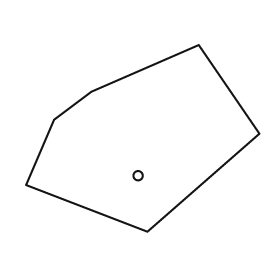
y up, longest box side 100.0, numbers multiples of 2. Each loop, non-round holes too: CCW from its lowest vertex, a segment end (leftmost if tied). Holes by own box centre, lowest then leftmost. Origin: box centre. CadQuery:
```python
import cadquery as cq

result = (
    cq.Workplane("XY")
    .moveTo(2.0, -40.0)
    .lineTo(50.0, 2.0)
    .lineTo(24.0, 40.0)
    .lineTo(-22.0, 20.0)
    .lineTo(-38.0, 8.0)
    .lineTo(-50.0, -20.0)
    .close()
    .moveTo(-2.0, -16.0)
    .circle(2.0)
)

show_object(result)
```